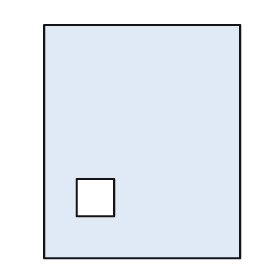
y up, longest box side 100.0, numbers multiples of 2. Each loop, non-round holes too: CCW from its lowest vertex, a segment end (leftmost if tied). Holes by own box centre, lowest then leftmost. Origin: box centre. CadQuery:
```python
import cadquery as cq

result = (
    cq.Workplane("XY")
    .moveTo(-42.0, -50.0)
    .lineTo(42.0, -50.0)
    .lineTo(42.0, 50.0)
    .lineTo(-42.0, 50.0)
    .close()
    .moveTo(-28.0, -32.0)
    .lineTo(-12.0, -32.0)
    .lineTo(-12.0, -16.0)
    .lineTo(-28.0, -16.0)
    .close()
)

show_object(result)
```